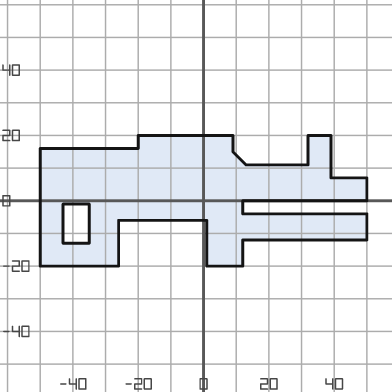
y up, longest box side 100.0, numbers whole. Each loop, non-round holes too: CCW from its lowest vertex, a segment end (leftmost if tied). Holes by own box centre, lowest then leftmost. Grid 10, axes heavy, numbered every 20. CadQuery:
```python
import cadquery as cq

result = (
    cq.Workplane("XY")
    .moveTo(-50.0, -20.0)
    .lineTo(-26.0, -20.0)
    .lineTo(-26.0, -6.0)
    .lineTo(1.0, -6.0)
    .lineTo(1.0, -20.0)
    .lineTo(12.0, -20.0)
    .lineTo(12.0, -12.0)
    .lineTo(50.0, -12.0)
    .lineTo(50.0, -4.0)
    .lineTo(12.0, -4.0)
    .lineTo(12.0, 0.0)
    .lineTo(50.0, 0.0)
    .lineTo(50.0, 7.0)
    .lineTo(39.0, 7.0)
    .lineTo(39.0, 20.0)
    .lineTo(32.0, 20.0)
    .lineTo(32.0, 11.0)
    .lineTo(13.0, 11.0)
    .lineTo(9.0, 15.0)
    .lineTo(9.0, 20.0)
    .lineTo(-20.0, 20.0)
    .lineTo(-20.0, 16.0)
    .lineTo(-50.0, 16.0)
    .close()
    .moveTo(-43.0, -13.0)
    .lineTo(-35.0, -13.0)
    .lineTo(-35.0, -1.0)
    .lineTo(-43.0, -1.0)
    .close()
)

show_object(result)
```